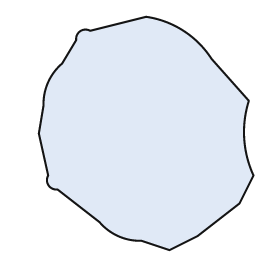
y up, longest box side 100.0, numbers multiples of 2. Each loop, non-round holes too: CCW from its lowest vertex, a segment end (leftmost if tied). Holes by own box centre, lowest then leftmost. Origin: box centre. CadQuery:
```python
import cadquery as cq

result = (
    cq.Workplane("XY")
    .moveTo(10.0, -50.0)
    .lineTo(22.0, -44.0)
    .lineTo(40.0, -30.0)
    .lineTo(46.0, -18.0)
    .threePointArc((42.0, -2.0), (44.0, 14.0))
    .lineTo(28.0, 32.0)
    .threePointArc((16.0, 44.0), (0.0, 50.0))
    .lineTo(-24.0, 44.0)
    .threePointArc((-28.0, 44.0), (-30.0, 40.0))
    .lineTo(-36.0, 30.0)
    .threePointArc((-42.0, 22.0), (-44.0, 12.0))
    .lineTo(-46.0, 0.0)
    .lineTo(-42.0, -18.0)
    .threePointArc((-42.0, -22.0), (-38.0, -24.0))
    .lineTo(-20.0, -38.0)
    .threePointArc((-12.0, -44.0), (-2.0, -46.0))
    .close()
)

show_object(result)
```